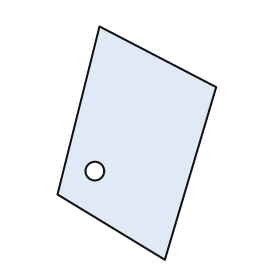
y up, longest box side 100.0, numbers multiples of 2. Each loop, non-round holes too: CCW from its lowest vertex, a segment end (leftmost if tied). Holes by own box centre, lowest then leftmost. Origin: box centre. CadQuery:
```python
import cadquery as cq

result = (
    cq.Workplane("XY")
    .moveTo(12.0, -50.0)
    .lineTo(34.0, 24.0)
    .lineTo(-16.0, 50.0)
    .lineTo(-34.0, -22.0)
    .close()
    .moveTo(-18.0, -12.0)
    .circle(4.0)
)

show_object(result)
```